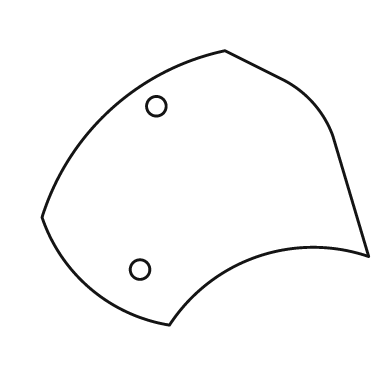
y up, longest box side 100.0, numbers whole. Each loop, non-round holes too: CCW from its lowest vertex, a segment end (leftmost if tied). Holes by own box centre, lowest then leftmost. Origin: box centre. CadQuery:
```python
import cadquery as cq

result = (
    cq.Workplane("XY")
    .moveTo(-11.0, -42.0)
    .threePointArc((16.0, -21.0), (50.0, -21.0))
    .lineTo(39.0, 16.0)
    .threePointArc((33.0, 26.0), (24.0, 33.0))
    .lineTo(6.0, 42.0)
    .threePointArc((-29.0, 24.0), (-50.0, -9.0))
    .threePointArc((-35.0, -31.0), (-11.0, -42.0))
    .close()
    .moveTo(-20.0, -25.0)
    .circle(3.0)
    .moveTo(-15.0, 25.0)
    .circle(3.0)
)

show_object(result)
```